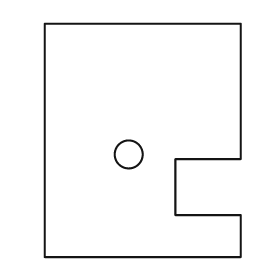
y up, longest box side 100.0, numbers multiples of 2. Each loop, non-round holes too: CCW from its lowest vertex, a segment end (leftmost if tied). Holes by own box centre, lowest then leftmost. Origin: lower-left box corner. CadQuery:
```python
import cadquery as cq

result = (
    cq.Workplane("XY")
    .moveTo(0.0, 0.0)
    .lineTo(84.0, 0.0)
    .lineTo(84.0, 18.0)
    .lineTo(56.0, 18.0)
    .lineTo(56.0, 42.0)
    .lineTo(84.0, 42.0)
    .lineTo(84.0, 100.0)
    .lineTo(0.0, 100.0)
    .close()
    .moveTo(36.0, 44.0)
    .circle(6.0)
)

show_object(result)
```